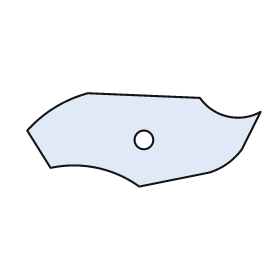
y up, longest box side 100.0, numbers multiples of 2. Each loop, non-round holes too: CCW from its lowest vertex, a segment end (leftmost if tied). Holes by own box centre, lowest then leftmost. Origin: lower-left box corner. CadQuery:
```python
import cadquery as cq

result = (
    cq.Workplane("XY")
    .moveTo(48.0, 0.0)
    .lineTo(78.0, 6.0)
    .threePointArc((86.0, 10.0), (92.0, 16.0))
    .lineTo(100.0, 32.0)
    .threePointArc((86.0, 30.0), (74.0, 38.0))
    .lineTo(26.0, 40.0)
    .threePointArc((12.0, 34.0), (0.0, 24.0))
    .lineTo(10.0, 8.0)
    .threePointArc((30.0, 8.0), (48.0, 0.0))
    .close()
    .moveTo(50.0, 20.0)
    .circle(4.0)
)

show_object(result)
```